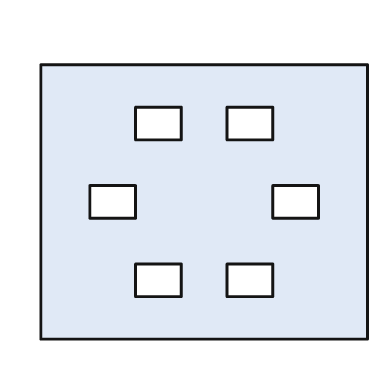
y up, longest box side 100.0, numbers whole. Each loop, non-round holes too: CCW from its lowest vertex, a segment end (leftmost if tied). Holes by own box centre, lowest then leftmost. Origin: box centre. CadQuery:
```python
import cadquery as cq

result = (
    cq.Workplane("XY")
    .moveTo(-50.0, -42.0)
    .lineTo(50.0, -42.0)
    .lineTo(50.0, 42.0)
    .lineTo(-50.0, 42.0)
    .close()
    .moveTo(-21.0, -29.0)
    .lineTo(-7.0, -29.0)
    .lineTo(-7.0, -19.0)
    .lineTo(-21.0, -19.0)
    .close()
    .moveTo(7.0, -29.0)
    .lineTo(21.0, -29.0)
    .lineTo(21.0, -19.0)
    .lineTo(7.0, -19.0)
    .close()
    .moveTo(-35.0, -5.0)
    .lineTo(-21.0, -5.0)
    .lineTo(-21.0, 5.0)
    .lineTo(-35.0, 5.0)
    .close()
    .moveTo(21.0, -5.0)
    .lineTo(35.0, -5.0)
    .lineTo(35.0, 5.0)
    .lineTo(21.0, 5.0)
    .close()
    .moveTo(-21.0, 19.0)
    .lineTo(-7.0, 19.0)
    .lineTo(-7.0, 29.0)
    .lineTo(-21.0, 29.0)
    .close()
    .moveTo(7.0, 19.0)
    .lineTo(21.0, 19.0)
    .lineTo(21.0, 29.0)
    .lineTo(7.0, 29.0)
    .close()
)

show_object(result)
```